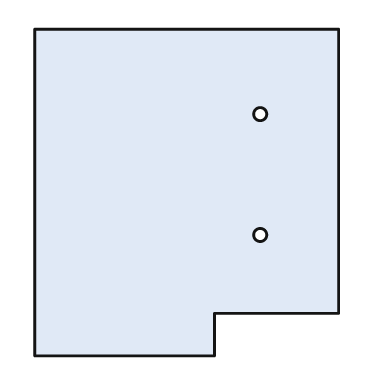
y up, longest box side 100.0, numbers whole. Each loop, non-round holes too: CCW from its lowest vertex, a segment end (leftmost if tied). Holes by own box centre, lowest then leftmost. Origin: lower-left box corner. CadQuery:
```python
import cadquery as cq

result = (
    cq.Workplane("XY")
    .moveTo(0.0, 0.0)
    .lineTo(55.0, 0.0)
    .lineTo(55.0, 13.0)
    .lineTo(93.0, 13.0)
    .lineTo(93.0, 100.0)
    .lineTo(0.0, 100.0)
    .close()
    .moveTo(69.0, 37.0)
    .circle(2.0)
    .moveTo(69.0, 74.0)
    .circle(2.0)
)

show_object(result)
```